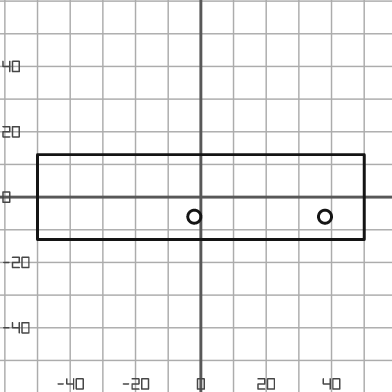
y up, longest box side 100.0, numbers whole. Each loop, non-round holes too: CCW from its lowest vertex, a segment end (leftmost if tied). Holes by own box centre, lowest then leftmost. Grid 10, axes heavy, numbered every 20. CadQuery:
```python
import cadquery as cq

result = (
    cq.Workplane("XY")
    .moveTo(-50.0, -13.0)
    .lineTo(50.0, -13.0)
    .lineTo(50.0, 13.0)
    .lineTo(-50.0, 13.0)
    .close()
    .moveTo(-2.0, -6.0)
    .circle(2.0)
    .moveTo(38.0, -6.0)
    .circle(2.0)
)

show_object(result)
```